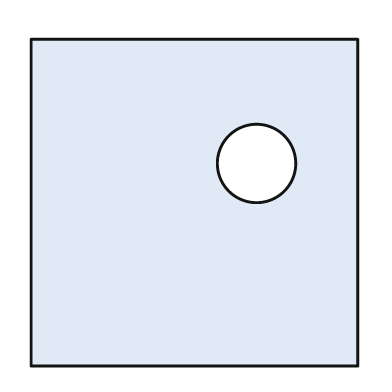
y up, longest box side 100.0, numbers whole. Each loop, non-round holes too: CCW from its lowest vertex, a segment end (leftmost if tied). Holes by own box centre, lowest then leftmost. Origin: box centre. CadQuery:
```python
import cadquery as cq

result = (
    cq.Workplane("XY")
    .moveTo(-50.0, -50.0)
    .lineTo(50.0, -50.0)
    .lineTo(50.0, 50.0)
    .lineTo(-50.0, 50.0)
    .close()
    .moveTo(19.0, 12.0)
    .circle(12.0)
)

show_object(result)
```